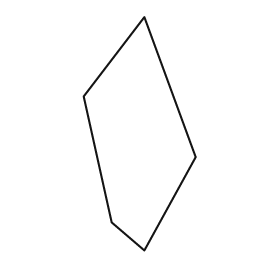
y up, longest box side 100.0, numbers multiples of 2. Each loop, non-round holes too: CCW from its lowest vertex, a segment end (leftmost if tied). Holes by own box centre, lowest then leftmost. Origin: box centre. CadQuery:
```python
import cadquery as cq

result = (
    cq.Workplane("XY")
    .moveTo(2.0, -50.0)
    .lineTo(24.0, -10.0)
    .lineTo(2.0, 50.0)
    .lineTo(-24.0, 16.0)
    .lineTo(-12.0, -38.0)
    .close()
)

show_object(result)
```